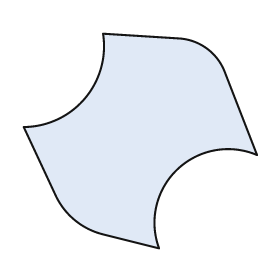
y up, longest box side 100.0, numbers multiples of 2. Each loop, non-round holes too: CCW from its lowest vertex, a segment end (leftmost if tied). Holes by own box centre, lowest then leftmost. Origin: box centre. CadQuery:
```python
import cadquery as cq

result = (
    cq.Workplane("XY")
    .moveTo(8.0, -46.0)
    .threePointArc((16.0, -12.0), (50.0, -6.0))
    .lineTo(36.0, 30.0)
    .threePointArc((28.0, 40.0), (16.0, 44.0))
    .lineTo(-16.0, 46.0)
    .threePointArc((-24.0, 18.0), (-50.0, 6.0))
    .lineTo(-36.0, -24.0)
    .threePointArc((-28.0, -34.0), (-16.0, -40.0))
    .close()
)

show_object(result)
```